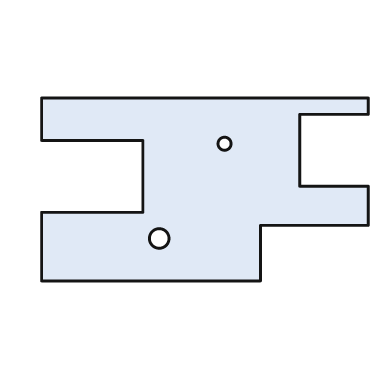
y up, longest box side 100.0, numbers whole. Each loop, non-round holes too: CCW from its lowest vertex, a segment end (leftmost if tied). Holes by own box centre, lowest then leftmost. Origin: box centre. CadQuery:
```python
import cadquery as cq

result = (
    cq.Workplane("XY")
    .moveTo(-50.0, -28.0)
    .lineTo(17.0, -28.0)
    .lineTo(17.0, -11.0)
    .lineTo(50.0, -11.0)
    .lineTo(50.0, 1.0)
    .lineTo(29.0, 1.0)
    .lineTo(29.0, 23.0)
    .lineTo(50.0, 23.0)
    .lineTo(50.0, 28.0)
    .lineTo(-50.0, 28.0)
    .lineTo(-50.0, 15.0)
    .lineTo(-19.0, 15.0)
    .lineTo(-19.0, -7.0)
    .lineTo(-50.0, -7.0)
    .close()
    .moveTo(-14.0, -15.0)
    .circle(3.0)
    .moveTo(6.0, 14.0)
    .circle(2.0)
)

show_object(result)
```